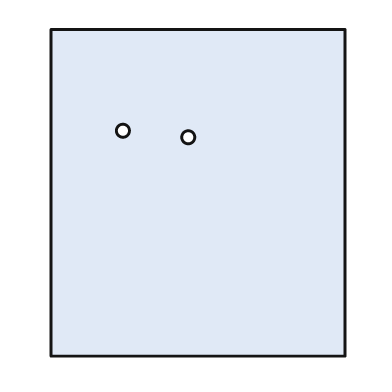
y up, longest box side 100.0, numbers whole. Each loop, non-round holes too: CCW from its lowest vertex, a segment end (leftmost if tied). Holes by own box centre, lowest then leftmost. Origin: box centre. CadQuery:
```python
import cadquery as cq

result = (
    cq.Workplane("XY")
    .moveTo(-45.0, -50.0)
    .lineTo(45.0, -50.0)
    .lineTo(45.0, 50.0)
    .lineTo(-45.0, 50.0)
    .close()
    .moveTo(-3.0, 17.0)
    .circle(2.0)
    .moveTo(-23.0, 19.0)
    .circle(2.0)
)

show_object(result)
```